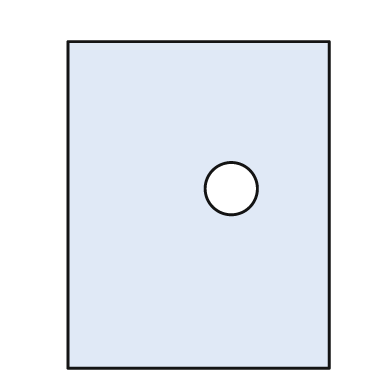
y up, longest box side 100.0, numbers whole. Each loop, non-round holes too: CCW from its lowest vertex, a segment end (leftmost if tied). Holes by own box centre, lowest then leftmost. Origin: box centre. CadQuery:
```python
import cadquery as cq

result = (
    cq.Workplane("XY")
    .moveTo(-40.0, -50.0)
    .lineTo(40.0, -50.0)
    .lineTo(40.0, 50.0)
    .lineTo(-40.0, 50.0)
    .close()
    .moveTo(10.0, 5.0)
    .circle(8.0)
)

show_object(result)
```